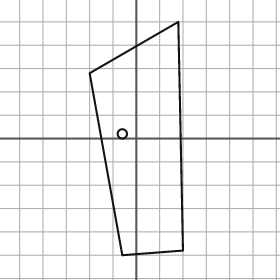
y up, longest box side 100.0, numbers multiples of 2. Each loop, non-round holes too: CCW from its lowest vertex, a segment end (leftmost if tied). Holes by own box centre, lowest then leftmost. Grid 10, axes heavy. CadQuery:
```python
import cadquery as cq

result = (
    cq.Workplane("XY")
    .moveTo(-6.0, -50.0)
    .lineTo(20.0, -48.0)
    .lineTo(18.0, 50.0)
    .lineTo(-20.0, 28.0)
    .close()
    .moveTo(-6.0, 2.0)
    .circle(2.0)
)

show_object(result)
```